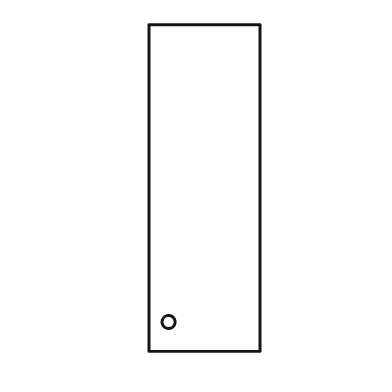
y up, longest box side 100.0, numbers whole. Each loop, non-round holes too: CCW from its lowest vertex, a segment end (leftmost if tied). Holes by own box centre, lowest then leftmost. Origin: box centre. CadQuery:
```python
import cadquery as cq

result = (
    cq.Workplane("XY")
    .moveTo(-17.0, -50.0)
    .lineTo(17.0, -50.0)
    .lineTo(17.0, 50.0)
    .lineTo(-17.0, 50.0)
    .close()
    .moveTo(-11.0, -41.0)
    .circle(2.0)
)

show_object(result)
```